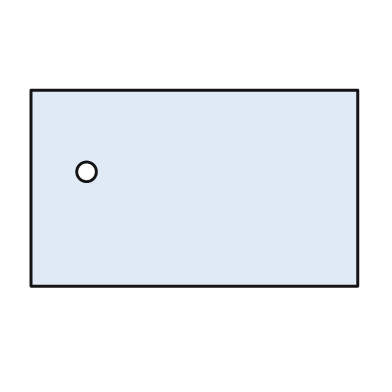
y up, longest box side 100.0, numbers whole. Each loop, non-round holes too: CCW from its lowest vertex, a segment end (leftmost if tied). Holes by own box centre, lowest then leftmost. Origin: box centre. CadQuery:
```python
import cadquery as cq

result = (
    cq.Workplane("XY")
    .moveTo(-50.0, -30.0)
    .lineTo(50.0, -30.0)
    .lineTo(50.0, 30.0)
    .lineTo(-50.0, 30.0)
    .close()
    .moveTo(-33.0, 5.0)
    .circle(3.0)
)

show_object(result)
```